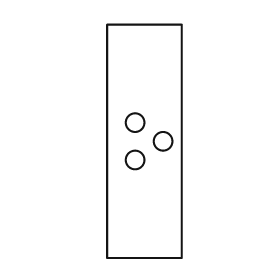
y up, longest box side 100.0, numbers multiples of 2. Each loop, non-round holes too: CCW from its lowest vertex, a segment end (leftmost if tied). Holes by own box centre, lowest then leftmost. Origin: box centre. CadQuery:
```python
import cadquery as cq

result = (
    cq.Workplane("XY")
    .moveTo(-16.0, -50.0)
    .lineTo(16.0, -50.0)
    .lineTo(16.0, 50.0)
    .lineTo(-16.0, 50.0)
    .close()
    .moveTo(-4.0, -8.0)
    .circle(4.0)
    .moveTo(8.0, 0.0)
    .circle(4.0)
    .moveTo(-4.0, 8.0)
    .circle(4.0)
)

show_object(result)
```